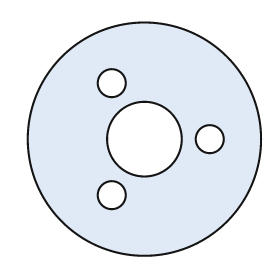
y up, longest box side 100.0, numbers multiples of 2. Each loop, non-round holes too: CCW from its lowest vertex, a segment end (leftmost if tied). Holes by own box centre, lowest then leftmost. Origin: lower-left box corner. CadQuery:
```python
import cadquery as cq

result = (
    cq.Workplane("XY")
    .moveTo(50.0, 50.0)
    .circle(50.0)
    .moveTo(36.0, 26.0)
    .circle(6.0)
    .moveTo(50.0, 50.0)
    .circle(16.0)
    .moveTo(78.0, 50.0)
    .circle(6.0)
    .moveTo(36.0, 74.0)
    .circle(6.0)
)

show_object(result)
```